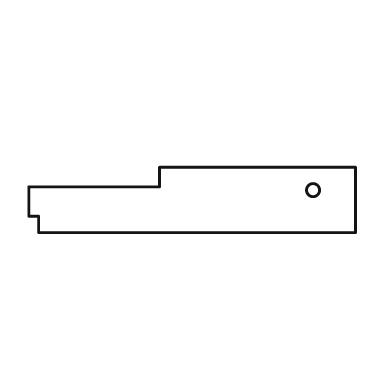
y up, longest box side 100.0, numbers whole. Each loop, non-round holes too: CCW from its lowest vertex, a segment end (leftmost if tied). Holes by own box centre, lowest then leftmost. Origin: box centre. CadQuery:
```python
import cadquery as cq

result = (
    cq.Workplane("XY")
    .moveTo(-47.0, -10.0)
    .lineTo(50.0, -10.0)
    .lineTo(50.0, 10.0)
    .lineTo(-10.0, 10.0)
    .lineTo(-10.0, 4.0)
    .lineTo(-50.0, 4.0)
    .lineTo(-50.0, -5.0)
    .lineTo(-47.0, -5.0)
    .close()
    .moveTo(37.0, 3.0)
    .circle(2.0)
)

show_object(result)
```